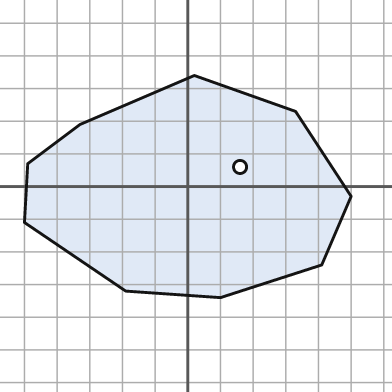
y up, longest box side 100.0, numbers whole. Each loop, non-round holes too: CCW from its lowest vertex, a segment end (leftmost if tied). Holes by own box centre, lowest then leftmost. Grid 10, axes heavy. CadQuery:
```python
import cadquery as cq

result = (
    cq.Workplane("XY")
    .moveTo(10.0, -34.0)
    .lineTo(41.0, -24.0)
    .lineTo(50.0, -3.0)
    .lineTo(33.0, 23.0)
    .lineTo(2.0, 34.0)
    .lineTo(-33.0, 19.0)
    .lineTo(-49.0, 7.0)
    .lineTo(-50.0, -11.0)
    .lineTo(-19.0, -32.0)
    .close()
    .moveTo(16.0, 6.0)
    .circle(2.0)
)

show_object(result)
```